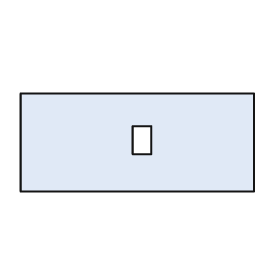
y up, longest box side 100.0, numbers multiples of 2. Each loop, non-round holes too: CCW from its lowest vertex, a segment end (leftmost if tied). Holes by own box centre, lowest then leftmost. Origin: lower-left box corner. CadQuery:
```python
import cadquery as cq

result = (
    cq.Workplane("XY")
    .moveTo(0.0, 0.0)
    .lineTo(100.0, 0.0)
    .lineTo(100.0, 42.0)
    .lineTo(0.0, 42.0)
    .close()
    .moveTo(48.0, 16.0)
    .lineTo(56.0, 16.0)
    .lineTo(56.0, 28.0)
    .lineTo(48.0, 28.0)
    .close()
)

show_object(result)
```